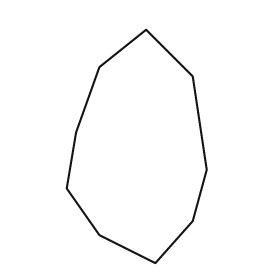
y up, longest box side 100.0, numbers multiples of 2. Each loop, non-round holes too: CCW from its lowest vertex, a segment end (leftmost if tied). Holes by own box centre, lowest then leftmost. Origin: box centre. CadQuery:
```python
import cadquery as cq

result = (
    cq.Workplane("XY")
    .moveTo(8.0, -50.0)
    .lineTo(24.0, -32.0)
    .lineTo(30.0, -10.0)
    .lineTo(24.0, 30.0)
    .lineTo(4.0, 50.0)
    .lineTo(-16.0, 34.0)
    .lineTo(-26.0, 6.0)
    .lineTo(-30.0, -18.0)
    .lineTo(-16.0, -38.0)
    .close()
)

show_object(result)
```